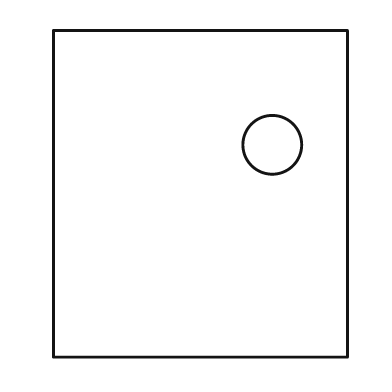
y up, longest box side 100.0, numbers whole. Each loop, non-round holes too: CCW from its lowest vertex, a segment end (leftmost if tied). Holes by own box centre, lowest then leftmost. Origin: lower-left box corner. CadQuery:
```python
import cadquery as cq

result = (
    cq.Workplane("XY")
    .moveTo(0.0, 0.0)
    .lineTo(90.0, 0.0)
    .lineTo(90.0, 100.0)
    .lineTo(0.0, 100.0)
    .close()
    .moveTo(67.0, 65.0)
    .circle(9.0)
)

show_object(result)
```